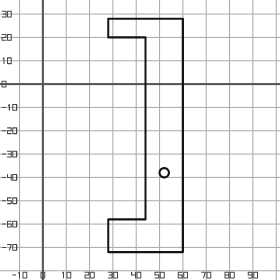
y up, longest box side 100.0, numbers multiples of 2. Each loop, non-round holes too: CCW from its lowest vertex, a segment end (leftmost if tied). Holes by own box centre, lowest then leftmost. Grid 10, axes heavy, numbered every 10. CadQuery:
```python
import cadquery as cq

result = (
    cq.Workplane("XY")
    .moveTo(28.0, -72.0)
    .lineTo(60.0, -72.0)
    .lineTo(60.0, 28.0)
    .lineTo(28.0, 28.0)
    .lineTo(28.0, 20.0)
    .lineTo(44.0, 20.0)
    .lineTo(44.0, -58.0)
    .lineTo(28.0, -58.0)
    .close()
    .moveTo(52.0, -38.0)
    .circle(2.0)
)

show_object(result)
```